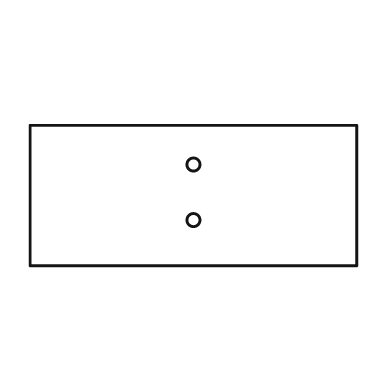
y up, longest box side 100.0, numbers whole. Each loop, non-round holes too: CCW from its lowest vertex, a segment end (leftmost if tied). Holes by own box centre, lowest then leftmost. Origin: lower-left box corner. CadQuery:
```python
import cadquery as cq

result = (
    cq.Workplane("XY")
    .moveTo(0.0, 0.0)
    .lineTo(100.0, 0.0)
    .lineTo(100.0, 43.0)
    .lineTo(0.0, 43.0)
    .close()
    .moveTo(50.0, 14.0)
    .circle(2.0)
    .moveTo(50.0, 31.0)
    .circle(2.0)
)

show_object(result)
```